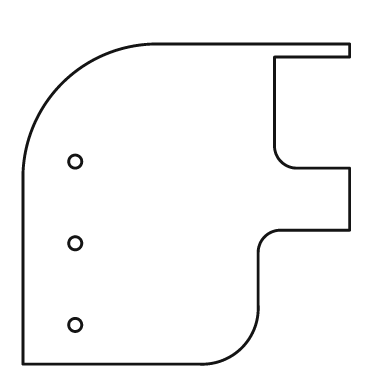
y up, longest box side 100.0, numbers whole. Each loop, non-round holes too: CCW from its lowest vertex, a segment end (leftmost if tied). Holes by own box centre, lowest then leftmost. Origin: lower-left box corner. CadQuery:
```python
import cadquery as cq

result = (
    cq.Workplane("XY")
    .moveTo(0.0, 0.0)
    .lineTo(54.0, 0.0)
    .threePointArc((67.0, 5.0), (72.0, 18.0))
    .lineTo(72.0, 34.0)
    .threePointArc((74.0, 39.0), (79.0, 41.0))
    .lineTo(100.0, 41.0)
    .lineTo(100.0, 60.0)
    .lineTo(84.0, 60.0)
    .threePointArc((79.0, 62.0), (77.0, 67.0))
    .lineTo(77.0, 94.0)
    .lineTo(100.0, 94.0)
    .lineTo(100.0, 98.0)
    .lineTo(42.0, 98.0)
    .threePointArc((12.0, 86.0), (0.0, 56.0))
    .close()
    .moveTo(16.0, 12.0)
    .circle(2.0)
    .moveTo(16.0, 37.0)
    .circle(2.0)
    .moveTo(16.0, 62.0)
    .circle(2.0)
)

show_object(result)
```